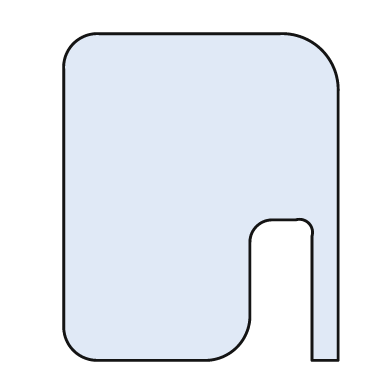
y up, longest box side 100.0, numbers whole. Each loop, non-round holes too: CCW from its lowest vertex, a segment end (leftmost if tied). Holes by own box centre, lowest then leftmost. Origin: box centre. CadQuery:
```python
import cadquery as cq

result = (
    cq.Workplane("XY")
    .moveTo(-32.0, -50.0)
    .lineTo(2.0, -50.0)
    .threePointArc((11.0, -46.0), (15.0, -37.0))
    .lineTo(15.0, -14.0)
    .threePointArc((17.0, -9.0), (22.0, -7.0))
    .lineTo(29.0, -7.0)
    .threePointArc((33.0, -8.0), (34.0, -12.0))
    .lineTo(34.0, -50.0)
    .lineTo(42.0, -50.0)
    .lineTo(42.0, 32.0)
    .threePointArc((37.0, 45.0), (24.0, 50.0))
    .lineTo(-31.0, 50.0)
    .threePointArc((-39.0, 47.0), (-42.0, 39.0))
    .lineTo(-42.0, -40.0)
    .threePointArc((-39.0, -47.0), (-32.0, -50.0))
    .close()
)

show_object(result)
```